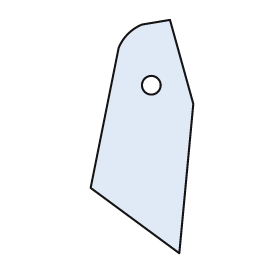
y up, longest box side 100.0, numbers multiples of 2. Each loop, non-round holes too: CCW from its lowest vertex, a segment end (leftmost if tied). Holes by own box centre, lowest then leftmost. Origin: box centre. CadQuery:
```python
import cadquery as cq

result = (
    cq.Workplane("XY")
    .moveTo(16.0, -50.0)
    .lineTo(22.0, 14.0)
    .lineTo(12.0, 50.0)
    .lineTo(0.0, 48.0)
    .threePointArc((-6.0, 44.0), (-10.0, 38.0))
    .lineTo(-22.0, -22.0)
    .close()
    .moveTo(4.0, 22.0)
    .circle(4.0)
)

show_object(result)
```